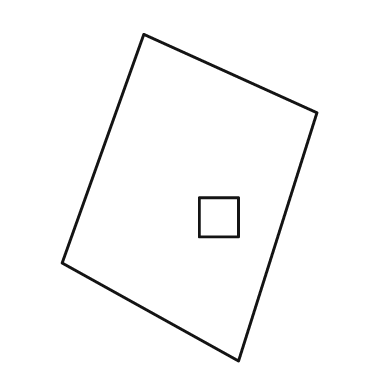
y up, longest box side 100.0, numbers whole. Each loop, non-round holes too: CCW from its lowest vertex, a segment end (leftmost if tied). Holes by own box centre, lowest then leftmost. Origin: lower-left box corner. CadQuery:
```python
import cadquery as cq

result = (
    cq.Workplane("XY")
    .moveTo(54.0, 0.0)
    .lineTo(78.0, 76.0)
    .lineTo(25.0, 100.0)
    .lineTo(0.0, 30.0)
    .close()
    .moveTo(42.0, 38.0)
    .lineTo(54.0, 38.0)
    .lineTo(54.0, 50.0)
    .lineTo(42.0, 50.0)
    .close()
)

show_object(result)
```